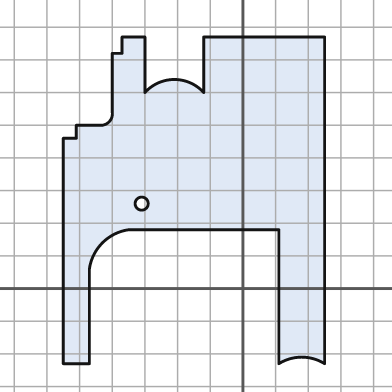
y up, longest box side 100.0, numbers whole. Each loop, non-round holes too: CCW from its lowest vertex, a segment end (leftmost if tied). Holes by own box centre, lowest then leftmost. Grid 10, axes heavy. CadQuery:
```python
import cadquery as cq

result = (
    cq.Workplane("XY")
    .moveTo(-55.0, -23.0)
    .lineTo(-47.0, -23.0)
    .lineTo(-47.0, 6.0)
    .threePointArc((-43.0, 14.0), (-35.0, 18.0))
    .lineTo(11.0, 18.0)
    .lineTo(11.0, -23.0)
    .threePointArc((18.0, -21.0), (25.0, -23.0))
    .lineTo(25.0, 77.0)
    .lineTo(-12.0, 77.0)
    .lineTo(-12.0, 60.0)
    .threePointArc((-21.0, 64.0), (-30.0, 60.0))
    .lineTo(-30.0, 77.0)
    .lineTo(-37.0, 77.0)
    .lineTo(-37.0, 72.0)
    .lineTo(-40.0, 72.0)
    .lineTo(-40.0, 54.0)
    .threePointArc((-41.0, 51.0), (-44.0, 50.0))
    .lineTo(-51.0, 50.0)
    .lineTo(-51.0, 46.0)
    .lineTo(-55.0, 46.0)
    .close()
    .moveTo(-31.0, 26.0)
    .circle(2.0)
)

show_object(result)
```